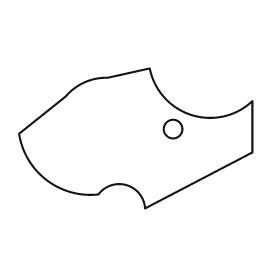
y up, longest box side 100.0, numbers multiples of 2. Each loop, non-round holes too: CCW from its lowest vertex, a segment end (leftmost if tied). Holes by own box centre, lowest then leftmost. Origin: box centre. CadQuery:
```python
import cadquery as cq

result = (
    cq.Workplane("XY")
    .moveTo(4.0, -30.0)
    .lineTo(50.0, -6.0)
    .lineTo(50.0, 16.0)
    .threePointArc((24.0, 10.0), (6.0, 30.0))
    .lineTo(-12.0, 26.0)
    .threePointArc((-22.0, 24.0), (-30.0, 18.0))
    .lineTo(-50.0, 2.0)
    .threePointArc((-38.0, -18.0), (-16.0, -24.0))
    .threePointArc((-4.0, -20.0), (4.0, -30.0))
    .close()
    .moveTo(16.0, 4.0)
    .circle(4.0)
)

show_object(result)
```